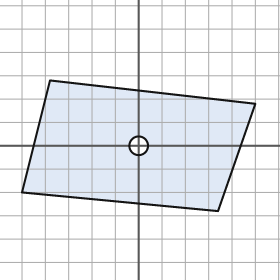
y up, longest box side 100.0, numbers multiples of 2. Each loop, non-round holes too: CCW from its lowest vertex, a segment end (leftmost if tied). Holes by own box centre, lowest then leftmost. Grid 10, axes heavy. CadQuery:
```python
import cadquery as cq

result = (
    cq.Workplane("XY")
    .moveTo(34.0, -28.0)
    .lineTo(50.0, 18.0)
    .lineTo(-38.0, 28.0)
    .lineTo(-50.0, -20.0)
    .close()
    .moveTo(0.0, 0.0)
    .circle(4.0)
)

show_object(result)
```